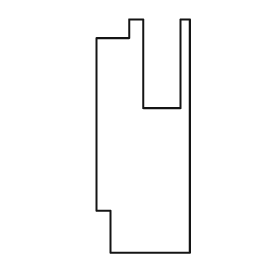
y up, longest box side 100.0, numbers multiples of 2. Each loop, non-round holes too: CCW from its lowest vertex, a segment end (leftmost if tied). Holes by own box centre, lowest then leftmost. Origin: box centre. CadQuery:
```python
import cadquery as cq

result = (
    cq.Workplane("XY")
    .moveTo(-14.0, -50.0)
    .lineTo(20.0, -50.0)
    .lineTo(20.0, 50.0)
    .lineTo(16.0, 50.0)
    .lineTo(16.0, 12.0)
    .lineTo(0.0, 12.0)
    .lineTo(0.0, 50.0)
    .lineTo(-6.0, 50.0)
    .lineTo(-6.0, 42.0)
    .lineTo(-20.0, 42.0)
    .lineTo(-20.0, -32.0)
    .lineTo(-14.0, -32.0)
    .close()
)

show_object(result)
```